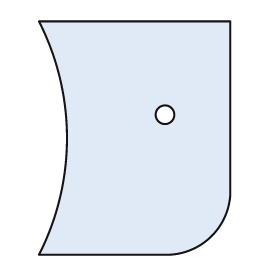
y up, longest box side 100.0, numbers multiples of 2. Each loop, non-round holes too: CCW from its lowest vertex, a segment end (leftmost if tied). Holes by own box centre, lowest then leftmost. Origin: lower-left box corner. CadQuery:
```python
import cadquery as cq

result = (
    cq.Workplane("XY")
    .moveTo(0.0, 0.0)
    .lineTo(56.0, 0.0)
    .threePointArc((74.0, 8.0), (82.0, 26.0))
    .lineTo(82.0, 100.0)
    .lineTo(0.0, 100.0)
    .threePointArc((12.0, 50.0), (0.0, 0.0))
    .close()
    .moveTo(54.0, 60.0)
    .circle(4.0)
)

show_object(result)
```